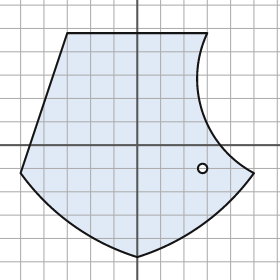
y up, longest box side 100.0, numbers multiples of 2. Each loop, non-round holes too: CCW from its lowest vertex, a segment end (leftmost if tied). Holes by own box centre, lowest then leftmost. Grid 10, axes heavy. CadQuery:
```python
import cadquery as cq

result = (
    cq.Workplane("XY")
    .moveTo(0.0, -48.0)
    .threePointArc((28.0, -34.0), (50.0, -12.0))
    .threePointArc((28.0, 14.0), (30.0, 48.0))
    .lineTo(-30.0, 48.0)
    .lineTo(-50.0, -12.0)
    .threePointArc((-28.0, -34.0), (0.0, -48.0))
    .close()
    .moveTo(28.0, -10.0)
    .circle(2.0)
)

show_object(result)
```